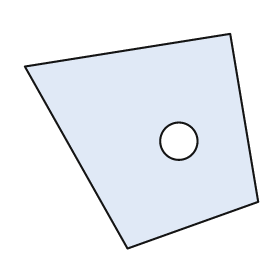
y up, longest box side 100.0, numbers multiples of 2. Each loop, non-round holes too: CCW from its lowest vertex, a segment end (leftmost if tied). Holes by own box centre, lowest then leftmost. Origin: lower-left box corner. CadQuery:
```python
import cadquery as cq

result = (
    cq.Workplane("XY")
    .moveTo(44.0, 0.0)
    .lineTo(100.0, 20.0)
    .lineTo(88.0, 92.0)
    .lineTo(0.0, 78.0)
    .close()
    .moveTo(66.0, 46.0)
    .circle(8.0)
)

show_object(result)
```